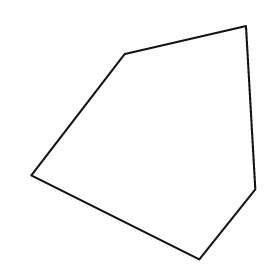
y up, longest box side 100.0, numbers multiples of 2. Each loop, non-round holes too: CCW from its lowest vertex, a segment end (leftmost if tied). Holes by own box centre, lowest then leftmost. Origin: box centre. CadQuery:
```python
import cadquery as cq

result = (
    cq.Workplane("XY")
    .moveTo(24.0, -50.0)
    .lineTo(48.0, -20.0)
    .lineTo(44.0, 50.0)
    .lineTo(-8.0, 38.0)
    .lineTo(-48.0, -14.0)
    .close()
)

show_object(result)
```